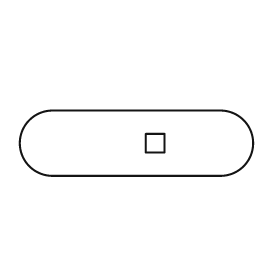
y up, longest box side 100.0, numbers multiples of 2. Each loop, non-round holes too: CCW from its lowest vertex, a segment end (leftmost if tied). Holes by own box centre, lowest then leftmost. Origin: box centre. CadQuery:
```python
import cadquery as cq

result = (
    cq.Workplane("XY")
    .moveTo(-36.0, -14.0)
    .lineTo(36.0, -14.0)
    .threePointArc((50.0, 0.0), (36.0, 14.0))
    .lineTo(-36.0, 14.0)
    .threePointArc((-50.0, 0.0), (-36.0, -14.0))
    .close()
    .moveTo(4.0, -4.0)
    .lineTo(12.0, -4.0)
    .lineTo(12.0, 4.0)
    .lineTo(4.0, 4.0)
    .close()
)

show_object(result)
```